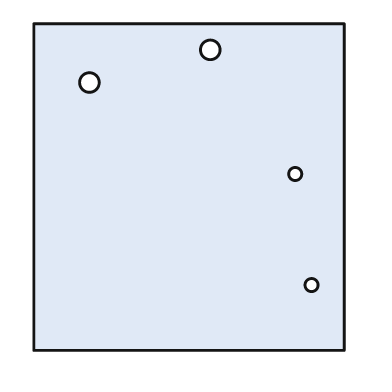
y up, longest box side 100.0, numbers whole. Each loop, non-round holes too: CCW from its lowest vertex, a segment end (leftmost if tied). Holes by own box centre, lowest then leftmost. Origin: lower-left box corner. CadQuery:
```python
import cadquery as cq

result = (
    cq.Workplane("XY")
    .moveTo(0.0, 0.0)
    .lineTo(95.0, 0.0)
    .lineTo(95.0, 100.0)
    .lineTo(0.0, 100.0)
    .close()
    .moveTo(85.0, 20.0)
    .circle(2.0)
    .moveTo(80.0, 54.0)
    .circle(2.0)
    .moveTo(17.0, 82.0)
    .circle(3.0)
    .moveTo(54.0, 92.0)
    .circle(3.0)
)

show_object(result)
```